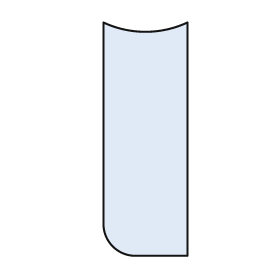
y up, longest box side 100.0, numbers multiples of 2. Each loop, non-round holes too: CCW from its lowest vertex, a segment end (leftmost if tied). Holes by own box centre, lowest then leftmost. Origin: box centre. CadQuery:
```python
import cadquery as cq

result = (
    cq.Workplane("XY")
    .moveTo(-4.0, -50.0)
    .lineTo(18.0, -50.0)
    .lineTo(18.0, 50.0)
    .threePointArc((0.0, 46.0), (-18.0, 50.0))
    .lineTo(-18.0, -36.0)
    .threePointArc((-14.0, -46.0), (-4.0, -50.0))
    .close()
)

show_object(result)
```